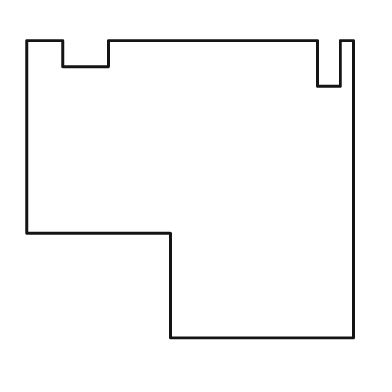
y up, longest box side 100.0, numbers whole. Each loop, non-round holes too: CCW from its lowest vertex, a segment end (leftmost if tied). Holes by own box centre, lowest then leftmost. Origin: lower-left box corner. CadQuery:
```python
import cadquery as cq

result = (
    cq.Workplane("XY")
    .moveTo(44.0, 0.0)
    .lineTo(100.0, 0.0)
    .lineTo(100.0, 91.0)
    .lineTo(96.0, 91.0)
    .lineTo(96.0, 77.0)
    .lineTo(89.0, 77.0)
    .lineTo(89.0, 91.0)
    .lineTo(25.0, 91.0)
    .lineTo(25.0, 83.0)
    .lineTo(11.0, 83.0)
    .lineTo(11.0, 91.0)
    .lineTo(0.0, 91.0)
    .lineTo(0.0, 32.0)
    .lineTo(44.0, 32.0)
    .close()
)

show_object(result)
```